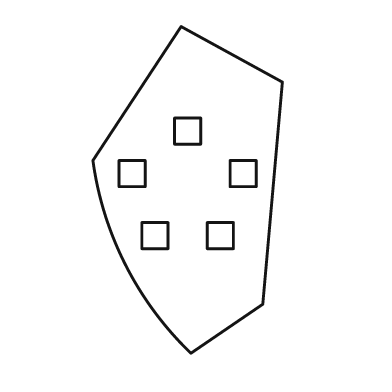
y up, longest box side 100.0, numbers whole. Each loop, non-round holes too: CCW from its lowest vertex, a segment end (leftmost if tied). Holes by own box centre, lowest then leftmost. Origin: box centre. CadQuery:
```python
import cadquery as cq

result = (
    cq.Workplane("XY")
    .moveTo(1.0, -50.0)
    .lineTo(23.0, -35.0)
    .lineTo(29.0, 33.0)
    .lineTo(-2.0, 50.0)
    .lineTo(-29.0, 9.0)
    .threePointArc((-19.0, -23.0), (1.0, -50.0))
    .close()
    .moveTo(-14.0, -18.0)
    .lineTo(-6.0, -18.0)
    .lineTo(-6.0, -10.0)
    .lineTo(-14.0, -10.0)
    .close()
    .moveTo(6.0, -18.0)
    .lineTo(14.0, -18.0)
    .lineTo(14.0, -10.0)
    .lineTo(6.0, -10.0)
    .close()
    .moveTo(-21.0, 1.0)
    .lineTo(-13.0, 1.0)
    .lineTo(-13.0, 9.0)
    .lineTo(-21.0, 9.0)
    .close()
    .moveTo(13.0, 1.0)
    .lineTo(21.0, 1.0)
    .lineTo(21.0, 9.0)
    .lineTo(13.0, 9.0)
    .close()
    .moveTo(-4.0, 14.0)
    .lineTo(4.0, 14.0)
    .lineTo(4.0, 22.0)
    .lineTo(-4.0, 22.0)
    .close()
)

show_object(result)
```